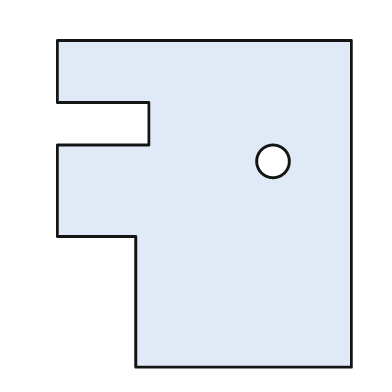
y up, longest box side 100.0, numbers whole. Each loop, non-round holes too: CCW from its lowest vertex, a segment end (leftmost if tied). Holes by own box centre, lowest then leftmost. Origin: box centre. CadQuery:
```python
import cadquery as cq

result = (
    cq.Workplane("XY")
    .moveTo(-21.0, -50.0)
    .lineTo(45.0, -50.0)
    .lineTo(45.0, 50.0)
    .lineTo(-45.0, 50.0)
    .lineTo(-45.0, 31.0)
    .lineTo(-17.0, 31.0)
    .lineTo(-17.0, 18.0)
    .lineTo(-45.0, 18.0)
    .lineTo(-45.0, -10.0)
    .lineTo(-21.0, -10.0)
    .close()
    .moveTo(21.0, 13.0)
    .circle(5.0)
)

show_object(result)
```